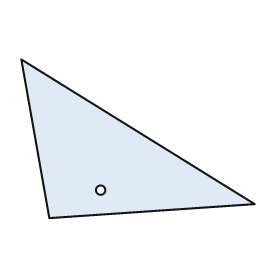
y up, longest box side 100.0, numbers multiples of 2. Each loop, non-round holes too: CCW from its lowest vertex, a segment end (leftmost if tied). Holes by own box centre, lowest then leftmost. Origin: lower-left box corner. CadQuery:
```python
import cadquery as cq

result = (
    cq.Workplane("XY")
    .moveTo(12.0, 0.0)
    .lineTo(100.0, 6.0)
    .lineTo(0.0, 68.0)
    .close()
    .moveTo(34.0, 12.0)
    .circle(2.0)
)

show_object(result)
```